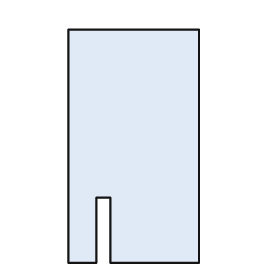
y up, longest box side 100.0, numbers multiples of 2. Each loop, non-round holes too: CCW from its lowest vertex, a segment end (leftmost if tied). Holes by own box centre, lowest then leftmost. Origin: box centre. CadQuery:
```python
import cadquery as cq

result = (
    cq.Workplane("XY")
    .moveTo(-28.0, -50.0)
    .lineTo(-16.0, -50.0)
    .lineTo(-16.0, -22.0)
    .lineTo(-10.0, -22.0)
    .lineTo(-10.0, -50.0)
    .lineTo(28.0, -50.0)
    .lineTo(28.0, 50.0)
    .lineTo(-28.0, 50.0)
    .close()
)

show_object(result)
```